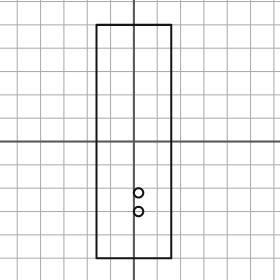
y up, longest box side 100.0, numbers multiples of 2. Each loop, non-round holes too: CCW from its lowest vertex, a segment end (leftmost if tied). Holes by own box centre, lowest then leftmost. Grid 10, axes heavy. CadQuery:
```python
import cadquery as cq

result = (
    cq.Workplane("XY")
    .moveTo(-16.0, -50.0)
    .lineTo(16.0, -50.0)
    .lineTo(16.0, 50.0)
    .lineTo(-16.0, 50.0)
    .close()
    .moveTo(2.0, -30.0)
    .circle(2.0)
    .moveTo(2.0, -22.0)
    .circle(2.0)
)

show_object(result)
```